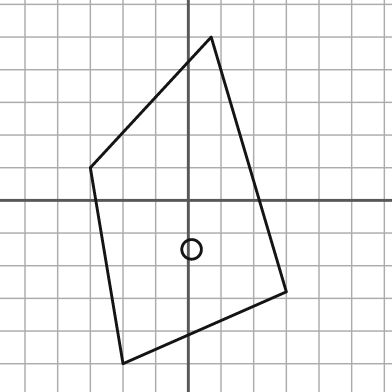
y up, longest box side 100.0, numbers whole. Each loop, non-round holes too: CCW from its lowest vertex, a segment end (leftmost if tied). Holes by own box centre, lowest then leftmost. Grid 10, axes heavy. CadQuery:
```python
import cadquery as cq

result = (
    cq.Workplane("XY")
    .moveTo(-20.0, -50.0)
    .lineTo(30.0, -28.0)
    .lineTo(7.0, 50.0)
    .lineTo(-30.0, 10.0)
    .close()
    .moveTo(1.0, -15.0)
    .circle(3.0)
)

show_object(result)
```